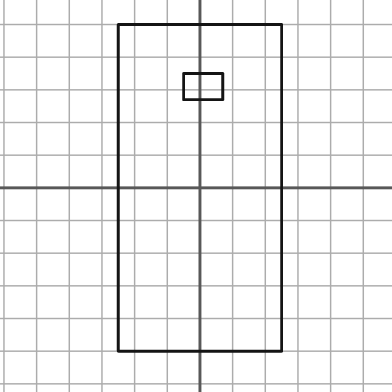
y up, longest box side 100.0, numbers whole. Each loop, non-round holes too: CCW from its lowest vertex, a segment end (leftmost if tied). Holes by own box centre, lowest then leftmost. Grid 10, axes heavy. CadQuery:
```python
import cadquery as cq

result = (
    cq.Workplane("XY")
    .moveTo(-25.0, -50.0)
    .lineTo(25.0, -50.0)
    .lineTo(25.0, 50.0)
    .lineTo(-25.0, 50.0)
    .close()
    .moveTo(-5.0, 27.0)
    .lineTo(7.0, 27.0)
    .lineTo(7.0, 35.0)
    .lineTo(-5.0, 35.0)
    .close()
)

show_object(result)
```